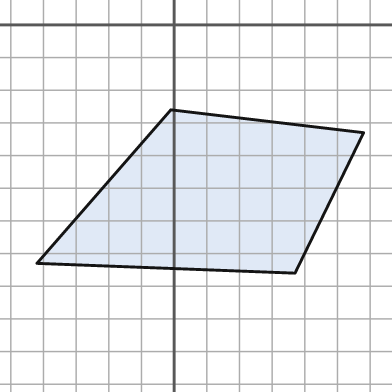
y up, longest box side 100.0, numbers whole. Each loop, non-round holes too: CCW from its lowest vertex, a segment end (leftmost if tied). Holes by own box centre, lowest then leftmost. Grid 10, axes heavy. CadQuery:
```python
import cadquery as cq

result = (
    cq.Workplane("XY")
    .moveTo(37.0, -76.0)
    .lineTo(58.0, -33.0)
    .lineTo(-1.0, -26.0)
    .lineTo(-42.0, -73.0)
    .close()
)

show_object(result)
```